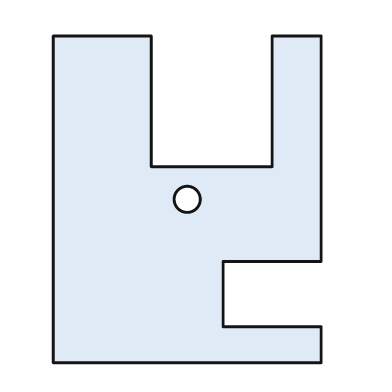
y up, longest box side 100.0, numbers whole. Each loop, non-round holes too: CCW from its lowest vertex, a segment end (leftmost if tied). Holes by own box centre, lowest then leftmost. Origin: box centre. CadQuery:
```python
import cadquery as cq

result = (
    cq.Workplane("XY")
    .moveTo(-41.0, -50.0)
    .lineTo(41.0, -50.0)
    .lineTo(41.0, -39.0)
    .lineTo(11.0, -39.0)
    .lineTo(11.0, -19.0)
    .lineTo(41.0, -19.0)
    .lineTo(41.0, 50.0)
    .lineTo(26.0, 50.0)
    .lineTo(26.0, 10.0)
    .lineTo(-11.0, 10.0)
    .lineTo(-11.0, 50.0)
    .lineTo(-41.0, 50.0)
    .close()
    .moveTo(0.0, 0.0)
    .circle(4.0)
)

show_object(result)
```